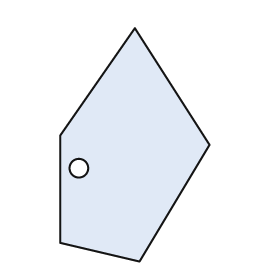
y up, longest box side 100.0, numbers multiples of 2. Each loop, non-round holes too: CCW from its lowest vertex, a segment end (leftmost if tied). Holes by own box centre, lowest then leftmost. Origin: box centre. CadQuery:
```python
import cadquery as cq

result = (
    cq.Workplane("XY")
    .moveTo(2.0, -50.0)
    .lineTo(32.0, 0.0)
    .lineTo(0.0, 50.0)
    .lineTo(-32.0, 4.0)
    .lineTo(-32.0, -42.0)
    .close()
    .moveTo(-24.0, -10.0)
    .circle(4.0)
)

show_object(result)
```